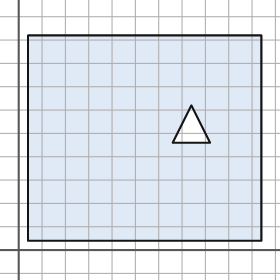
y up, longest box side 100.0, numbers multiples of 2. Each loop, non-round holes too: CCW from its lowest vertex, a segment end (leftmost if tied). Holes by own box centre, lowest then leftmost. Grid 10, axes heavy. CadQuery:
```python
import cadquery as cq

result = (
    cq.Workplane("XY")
    .moveTo(4.0, 4.0)
    .lineTo(104.0, 4.0)
    .lineTo(104.0, 92.0)
    .lineTo(4.0, 92.0)
    .close()
    .moveTo(66.0, 46.0)
    .lineTo(82.0, 46.0)
    .lineTo(74.0, 62.0)
    .close()
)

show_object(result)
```